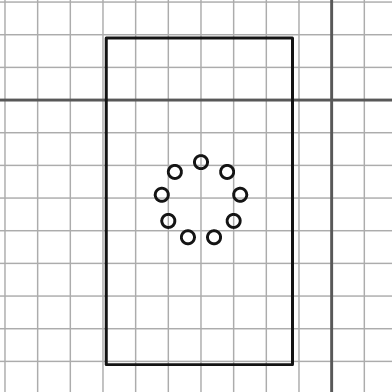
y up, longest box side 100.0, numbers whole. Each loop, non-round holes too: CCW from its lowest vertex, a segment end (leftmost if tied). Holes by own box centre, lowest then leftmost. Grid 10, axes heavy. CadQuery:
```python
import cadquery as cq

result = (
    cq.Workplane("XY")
    .moveTo(-69.0, -81.0)
    .lineTo(-12.0, -81.0)
    .lineTo(-12.0, 19.0)
    .lineTo(-69.0, 19.0)
    .close()
    .moveTo(-44.0, -42.0)
    .circle(2.0)
    .moveTo(-36.0, -42.0)
    .circle(2.0)
    .moveTo(-50.0, -37.0)
    .circle(2.0)
    .moveTo(-30.0, -37.0)
    .circle(2.0)
    .moveTo(-52.0, -29.0)
    .circle(2.0)
    .moveTo(-28.0, -29.0)
    .circle(2.0)
    .moveTo(-48.0, -22.0)
    .circle(2.0)
    .moveTo(-32.0, -22.0)
    .circle(2.0)
    .moveTo(-40.0, -19.0)
    .circle(2.0)
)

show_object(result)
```